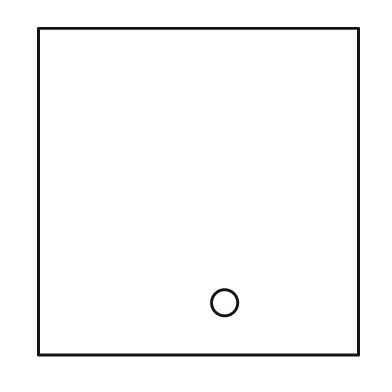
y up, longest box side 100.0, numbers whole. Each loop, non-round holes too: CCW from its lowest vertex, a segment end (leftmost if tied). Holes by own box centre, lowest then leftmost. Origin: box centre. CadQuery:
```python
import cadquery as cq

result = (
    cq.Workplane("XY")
    .moveTo(-49.0, -50.0)
    .lineTo(49.0, -50.0)
    .lineTo(49.0, 50.0)
    .lineTo(-49.0, 50.0)
    .close()
    .moveTo(8.0, -34.0)
    .circle(4.0)
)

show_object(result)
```